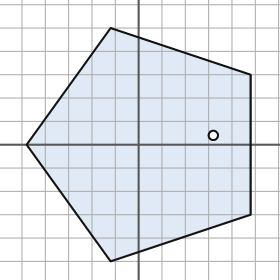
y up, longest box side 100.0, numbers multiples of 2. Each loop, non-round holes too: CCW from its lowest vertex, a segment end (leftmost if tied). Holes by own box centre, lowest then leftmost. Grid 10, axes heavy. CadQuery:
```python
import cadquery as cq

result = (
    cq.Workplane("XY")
    .moveTo(-12.0, -50.0)
    .lineTo(48.0, -30.0)
    .lineTo(48.0, 30.0)
    .lineTo(-12.0, 50.0)
    .lineTo(-48.0, 0.0)
    .close()
    .moveTo(32.0, 4.0)
    .circle(2.0)
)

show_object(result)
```